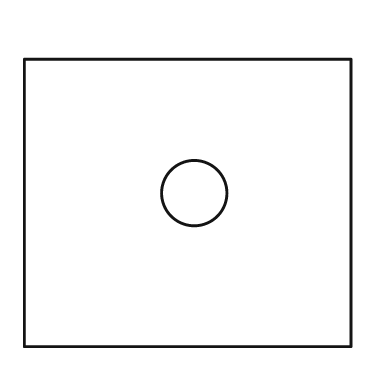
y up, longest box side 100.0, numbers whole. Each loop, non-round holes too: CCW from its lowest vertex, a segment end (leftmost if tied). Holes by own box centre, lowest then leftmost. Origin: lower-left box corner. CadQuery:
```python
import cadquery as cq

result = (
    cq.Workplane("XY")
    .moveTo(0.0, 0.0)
    .lineTo(100.0, 0.0)
    .lineTo(100.0, 88.0)
    .lineTo(0.0, 88.0)
    .close()
    .moveTo(52.0, 47.0)
    .circle(10.0)
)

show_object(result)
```